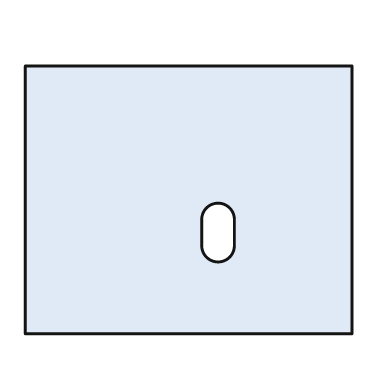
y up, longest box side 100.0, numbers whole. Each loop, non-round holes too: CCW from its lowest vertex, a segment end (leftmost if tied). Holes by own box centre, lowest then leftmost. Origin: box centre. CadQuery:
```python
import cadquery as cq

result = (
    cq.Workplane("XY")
    .moveTo(-50.0, -41.0)
    .lineTo(50.0, -41.0)
    .lineTo(50.0, 41.0)
    .lineTo(-50.0, 41.0)
    .close()
    .moveTo(4.0, -14.0)
    .threePointArc((9.0, -19.0), (14.0, -14.0))
    .lineTo(14.0, -6.0)
    .threePointArc((9.0, -1.0), (4.0, -6.0))
    .close()
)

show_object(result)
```